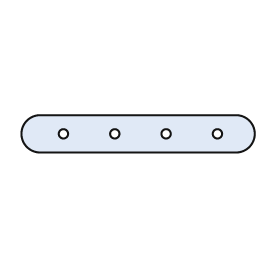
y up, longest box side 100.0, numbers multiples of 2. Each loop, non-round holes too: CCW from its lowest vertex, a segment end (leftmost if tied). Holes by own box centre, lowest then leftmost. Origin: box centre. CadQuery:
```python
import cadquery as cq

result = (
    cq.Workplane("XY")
    .moveTo(-42.0, -8.0)
    .lineTo(42.0, -8.0)
    .threePointArc((50.0, 0.0), (42.0, 8.0))
    .lineTo(-42.0, 8.0)
    .threePointArc((-50.0, 0.0), (-42.0, -8.0))
    .close()
    .moveTo(-32.0, 0.0)
    .circle(2.0)
    .moveTo(-10.0, 0.0)
    .circle(2.0)
    .moveTo(12.0, 0.0)
    .circle(2.0)
    .moveTo(34.0, 0.0)
    .circle(2.0)
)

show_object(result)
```